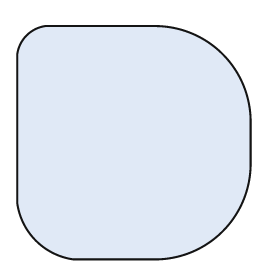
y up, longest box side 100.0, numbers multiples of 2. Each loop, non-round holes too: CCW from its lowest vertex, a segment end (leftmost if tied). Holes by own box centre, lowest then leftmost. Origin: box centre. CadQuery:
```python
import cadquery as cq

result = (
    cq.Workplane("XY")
    .moveTo(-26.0, -50.0)
    .lineTo(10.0, -50.0)
    .threePointArc((38.0, -38.0), (50.0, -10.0))
    .lineTo(50.0, 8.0)
    .threePointArc((38.0, 38.0), (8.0, 50.0))
    .lineTo(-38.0, 50.0)
    .threePointArc((-46.0, 46.0), (-50.0, 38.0))
    .lineTo(-50.0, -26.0)
    .threePointArc((-42.0, -42.0), (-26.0, -50.0))
    .close()
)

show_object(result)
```